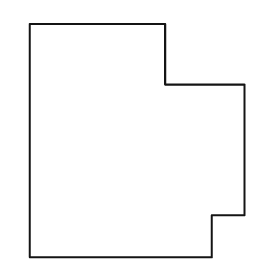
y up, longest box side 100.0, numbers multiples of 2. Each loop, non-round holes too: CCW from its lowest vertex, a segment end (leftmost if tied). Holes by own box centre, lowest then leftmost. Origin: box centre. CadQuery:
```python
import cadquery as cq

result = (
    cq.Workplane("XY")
    .moveTo(-46.0, -50.0)
    .lineTo(32.0, -50.0)
    .lineTo(32.0, -32.0)
    .lineTo(46.0, -32.0)
    .lineTo(46.0, 24.0)
    .lineTo(12.0, 24.0)
    .lineTo(12.0, 50.0)
    .lineTo(-46.0, 50.0)
    .close()
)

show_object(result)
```